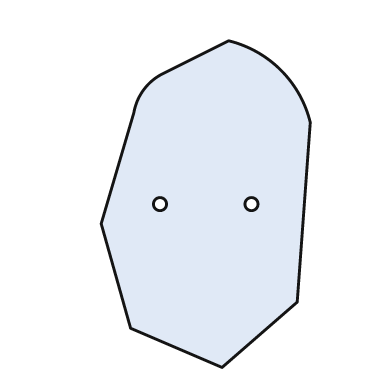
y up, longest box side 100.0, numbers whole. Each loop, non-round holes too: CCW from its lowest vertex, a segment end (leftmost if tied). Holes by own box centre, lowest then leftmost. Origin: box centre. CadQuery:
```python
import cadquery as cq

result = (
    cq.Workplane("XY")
    .moveTo(5.0, -50.0)
    .lineTo(28.0, -30.0)
    .lineTo(32.0, 25.0)
    .threePointArc((23.0, 41.0), (7.0, 50.0))
    .lineTo(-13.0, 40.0)
    .threePointArc((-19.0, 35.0), (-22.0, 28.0))
    .lineTo(-32.0, -6.0)
    .lineTo(-23.0, -38.0)
    .close()
    .moveTo(-14.0, 0.0)
    .circle(2.0)
    .moveTo(14.0, 0.0)
    .circle(2.0)
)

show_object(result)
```